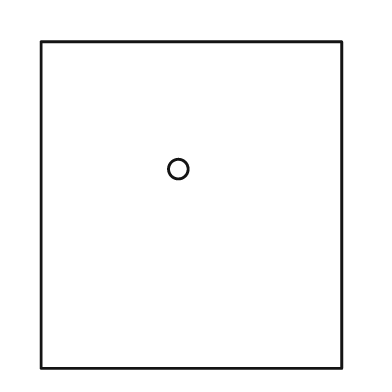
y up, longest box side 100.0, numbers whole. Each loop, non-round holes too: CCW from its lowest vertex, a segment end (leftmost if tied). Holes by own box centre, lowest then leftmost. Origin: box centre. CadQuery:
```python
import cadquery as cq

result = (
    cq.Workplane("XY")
    .moveTo(-46.0, -50.0)
    .lineTo(46.0, -50.0)
    .lineTo(46.0, 50.0)
    .lineTo(-46.0, 50.0)
    .close()
    .moveTo(-4.0, 11.0)
    .circle(3.0)
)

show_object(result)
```